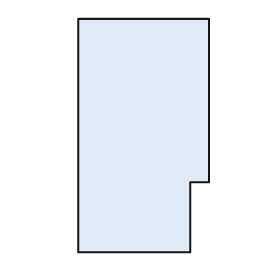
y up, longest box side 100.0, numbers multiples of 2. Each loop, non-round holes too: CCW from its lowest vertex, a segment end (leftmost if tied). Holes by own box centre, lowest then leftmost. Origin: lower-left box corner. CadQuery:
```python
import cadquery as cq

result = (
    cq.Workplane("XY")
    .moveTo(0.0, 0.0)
    .lineTo(48.0, 0.0)
    .lineTo(48.0, 30.0)
    .lineTo(56.0, 30.0)
    .lineTo(56.0, 100.0)
    .lineTo(0.0, 100.0)
    .close()
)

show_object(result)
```